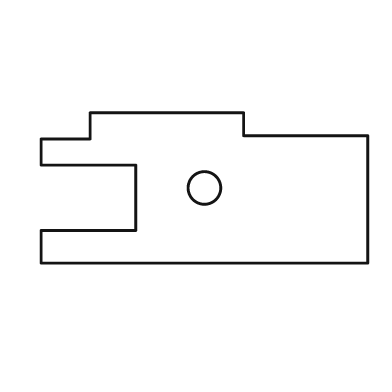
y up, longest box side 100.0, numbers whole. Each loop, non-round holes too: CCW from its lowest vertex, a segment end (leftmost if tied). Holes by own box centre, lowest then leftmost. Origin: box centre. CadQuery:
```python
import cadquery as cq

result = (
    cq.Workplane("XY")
    .moveTo(-50.0, -23.0)
    .lineTo(50.0, -23.0)
    .lineTo(50.0, 16.0)
    .lineTo(12.0, 16.0)
    .lineTo(12.0, 23.0)
    .lineTo(-35.0, 23.0)
    .lineTo(-35.0, 15.0)
    .lineTo(-50.0, 15.0)
    .lineTo(-50.0, 7.0)
    .lineTo(-21.0, 7.0)
    .lineTo(-21.0, -13.0)
    .lineTo(-50.0, -13.0)
    .close()
    .moveTo(0.0, 0.0)
    .circle(5.0)
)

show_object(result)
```